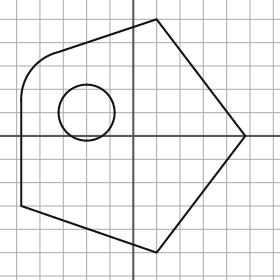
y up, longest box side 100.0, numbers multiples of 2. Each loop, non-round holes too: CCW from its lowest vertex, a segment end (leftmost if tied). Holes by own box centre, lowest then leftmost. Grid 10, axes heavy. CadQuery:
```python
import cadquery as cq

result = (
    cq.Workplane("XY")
    .moveTo(10.0, -50.0)
    .lineTo(48.0, 0.0)
    .lineTo(10.0, 50.0)
    .lineTo(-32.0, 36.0)
    .threePointArc((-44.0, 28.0), (-48.0, 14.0))
    .lineTo(-48.0, -30.0)
    .close()
    .moveTo(-20.0, 10.0)
    .circle(12.0)
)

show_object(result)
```